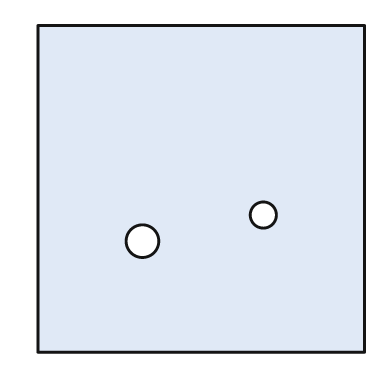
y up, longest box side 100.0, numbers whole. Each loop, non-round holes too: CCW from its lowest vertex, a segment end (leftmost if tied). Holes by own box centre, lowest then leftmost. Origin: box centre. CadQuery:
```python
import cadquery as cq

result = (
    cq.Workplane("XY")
    .moveTo(-50.0, -50.0)
    .lineTo(50.0, -50.0)
    .lineTo(50.0, 50.0)
    .lineTo(-50.0, 50.0)
    .close()
    .moveTo(-18.0, -16.0)
    .circle(5.0)
    .moveTo(19.0, -8.0)
    .circle(4.0)
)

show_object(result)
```